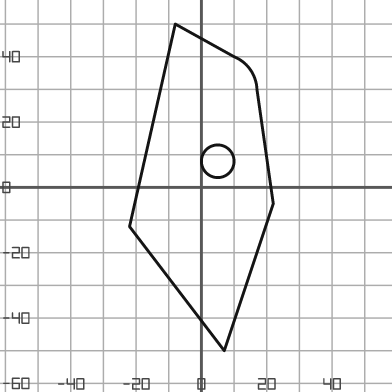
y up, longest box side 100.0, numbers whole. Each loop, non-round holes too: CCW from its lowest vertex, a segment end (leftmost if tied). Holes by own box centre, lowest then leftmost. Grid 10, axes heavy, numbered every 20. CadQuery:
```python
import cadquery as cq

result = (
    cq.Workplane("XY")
    .moveTo(7.0, -50.0)
    .lineTo(22.0, -5.0)
    .lineTo(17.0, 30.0)
    .threePointArc((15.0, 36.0), (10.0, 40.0))
    .lineTo(-8.0, 50.0)
    .lineTo(-22.0, -12.0)
    .close()
    .moveTo(5.0, 8.0)
    .circle(5.0)
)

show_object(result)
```